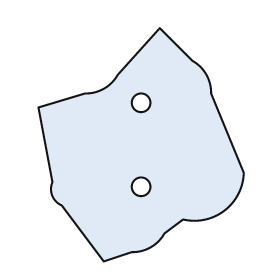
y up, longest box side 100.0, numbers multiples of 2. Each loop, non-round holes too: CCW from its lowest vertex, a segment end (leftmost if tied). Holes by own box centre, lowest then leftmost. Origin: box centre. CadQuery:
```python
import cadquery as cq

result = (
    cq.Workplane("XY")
    .moveTo(-16.0, -50.0)
    .lineTo(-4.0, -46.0)
    .threePointArc((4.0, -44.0), (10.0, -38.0))
    .lineTo(18.0, -32.0)
    .threePointArc((36.0, -28.0), (44.0, -12.0))
    .lineTo(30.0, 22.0)
    .threePointArc((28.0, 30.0), (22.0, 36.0))
    .lineTo(8.0, 50.0)
    .lineTo(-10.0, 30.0)
    .threePointArc((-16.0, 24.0), (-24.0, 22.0))
    .lineTo(-44.0, 16.0)
    .lineTo(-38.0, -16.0)
    .threePointArc((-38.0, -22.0), (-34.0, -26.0))
    .close()
    .moveTo(0.0, -18.0)
    .circle(4.0)
    .moveTo(0.0, 18.0)
    .circle(4.0)
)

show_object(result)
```